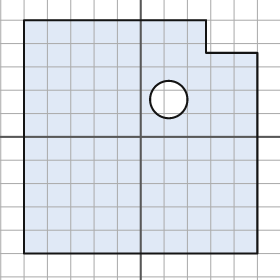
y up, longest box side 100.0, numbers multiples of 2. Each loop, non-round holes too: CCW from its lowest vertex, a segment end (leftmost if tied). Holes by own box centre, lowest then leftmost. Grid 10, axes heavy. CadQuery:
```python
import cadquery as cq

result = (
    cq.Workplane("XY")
    .moveTo(-50.0, -50.0)
    .lineTo(50.0, -50.0)
    .lineTo(50.0, 36.0)
    .lineTo(28.0, 36.0)
    .lineTo(28.0, 50.0)
    .lineTo(-50.0, 50.0)
    .close()
    .moveTo(12.0, 16.0)
    .circle(8.0)
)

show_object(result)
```